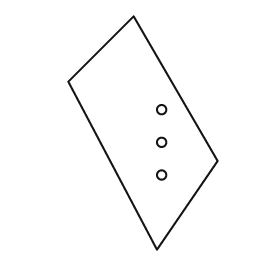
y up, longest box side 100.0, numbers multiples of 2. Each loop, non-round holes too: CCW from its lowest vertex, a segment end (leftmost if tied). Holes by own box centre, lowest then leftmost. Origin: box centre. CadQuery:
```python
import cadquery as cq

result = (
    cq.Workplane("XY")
    .moveTo(6.0, -50.0)
    .lineTo(32.0, -12.0)
    .lineTo(-4.0, 50.0)
    .lineTo(-32.0, 22.0)
    .close()
    .moveTo(8.0, -18.0)
    .circle(2.0)
    .moveTo(8.0, -4.0)
    .circle(2.0)
    .moveTo(8.0, 10.0)
    .circle(2.0)
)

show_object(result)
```